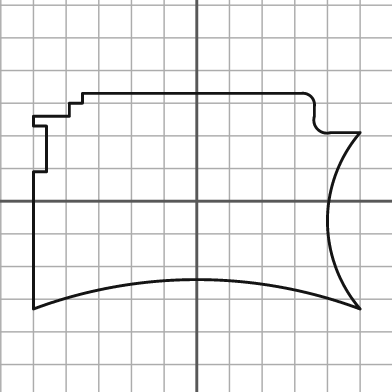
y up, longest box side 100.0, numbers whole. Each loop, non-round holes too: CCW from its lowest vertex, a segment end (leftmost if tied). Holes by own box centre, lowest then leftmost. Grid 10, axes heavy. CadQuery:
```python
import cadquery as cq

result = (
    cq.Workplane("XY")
    .moveTo(-50.0, -33.0)
    .threePointArc((0.0, -24.0), (50.0, -33.0))
    .threePointArc((40.0, -6.0), (50.0, 21.0))
    .lineTo(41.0, 21.0)
    .threePointArc((37.0, 22.0), (36.0, 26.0))
    .lineTo(36.0, 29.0)
    .threePointArc((35.0, 32.0), (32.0, 33.0))
    .lineTo(-35.0, 33.0)
    .lineTo(-35.0, 30.0)
    .lineTo(-39.0, 30.0)
    .lineTo(-39.0, 26.0)
    .lineTo(-50.0, 26.0)
    .lineTo(-50.0, 23.0)
    .lineTo(-46.0, 23.0)
    .lineTo(-46.0, 9.0)
    .lineTo(-50.0, 9.0)
    .close()
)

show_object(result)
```